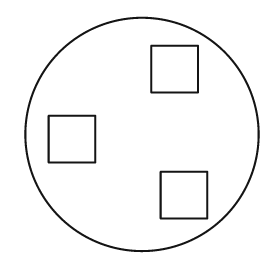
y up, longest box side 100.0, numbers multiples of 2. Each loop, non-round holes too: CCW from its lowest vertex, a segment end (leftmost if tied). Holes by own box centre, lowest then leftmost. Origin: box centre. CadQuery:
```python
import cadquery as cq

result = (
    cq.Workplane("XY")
    .moveTo(0.0, 0.0)
    .circle(50.0)
    .moveTo(8.0, -36.0)
    .lineTo(28.0, -36.0)
    .lineTo(28.0, -16.0)
    .lineTo(8.0, -16.0)
    .close()
    .moveTo(-40.0, -12.0)
    .lineTo(-20.0, -12.0)
    .lineTo(-20.0, 8.0)
    .lineTo(-40.0, 8.0)
    .close()
    .moveTo(4.0, 18.0)
    .lineTo(24.0, 18.0)
    .lineTo(24.0, 38.0)
    .lineTo(4.0, 38.0)
    .close()
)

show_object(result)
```